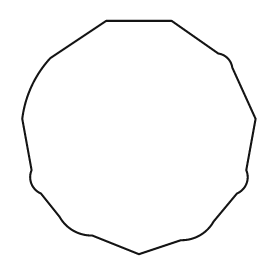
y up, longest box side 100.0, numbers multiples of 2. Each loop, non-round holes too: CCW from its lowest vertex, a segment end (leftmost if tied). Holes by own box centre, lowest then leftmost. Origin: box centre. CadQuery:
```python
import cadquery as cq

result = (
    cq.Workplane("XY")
    .moveTo(0.0, -50.0)
    .lineTo(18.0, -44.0)
    .threePointArc((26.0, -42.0), (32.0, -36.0))
    .lineTo(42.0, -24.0)
    .threePointArc((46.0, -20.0), (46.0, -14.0))
    .lineTo(50.0, 8.0)
    .lineTo(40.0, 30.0)
    .threePointArc((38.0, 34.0), (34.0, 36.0))
    .lineTo(14.0, 50.0)
    .lineTo(-14.0, 50.0)
    .lineTo(-38.0, 34.0)
    .threePointArc((-46.0, 22.0), (-50.0, 8.0))
    .lineTo(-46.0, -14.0)
    .threePointArc((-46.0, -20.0), (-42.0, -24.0))
    .lineTo(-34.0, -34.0)
    .threePointArc((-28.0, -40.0), (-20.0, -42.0))
    .close()
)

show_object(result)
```